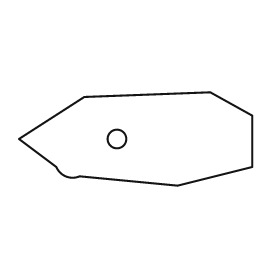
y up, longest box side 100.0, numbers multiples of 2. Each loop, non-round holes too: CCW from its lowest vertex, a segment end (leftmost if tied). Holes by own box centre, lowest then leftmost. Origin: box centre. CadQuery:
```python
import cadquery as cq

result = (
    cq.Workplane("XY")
    .moveTo(18.0, -20.0)
    .lineTo(50.0, -12.0)
    .lineTo(50.0, 10.0)
    .lineTo(32.0, 20.0)
    .lineTo(-22.0, 18.0)
    .lineTo(-50.0, 0.0)
    .lineTo(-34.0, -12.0)
    .threePointArc((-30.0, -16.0), (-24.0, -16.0))
    .close()
    .moveTo(-8.0, 0.0)
    .circle(4.0)
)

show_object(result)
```